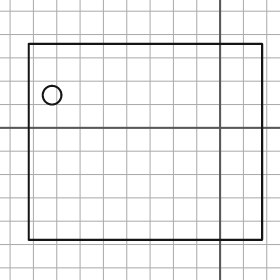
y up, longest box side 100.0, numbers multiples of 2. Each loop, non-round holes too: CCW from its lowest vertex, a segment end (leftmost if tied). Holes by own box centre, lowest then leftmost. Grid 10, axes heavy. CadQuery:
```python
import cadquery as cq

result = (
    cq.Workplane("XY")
    .moveTo(-82.0, -48.0)
    .lineTo(18.0, -48.0)
    .lineTo(18.0, 36.0)
    .lineTo(-82.0, 36.0)
    .close()
    .moveTo(-72.0, 14.0)
    .circle(4.0)
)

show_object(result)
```